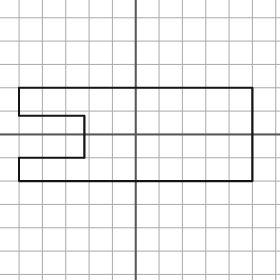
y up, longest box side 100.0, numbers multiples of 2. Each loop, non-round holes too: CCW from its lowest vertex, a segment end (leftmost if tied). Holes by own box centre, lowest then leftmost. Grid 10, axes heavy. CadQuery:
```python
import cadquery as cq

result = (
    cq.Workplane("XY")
    .moveTo(-50.0, -20.0)
    .lineTo(50.0, -20.0)
    .lineTo(50.0, 20.0)
    .lineTo(-50.0, 20.0)
    .lineTo(-50.0, 8.0)
    .lineTo(-22.0, 8.0)
    .lineTo(-22.0, -10.0)
    .lineTo(-50.0, -10.0)
    .close()
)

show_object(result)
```